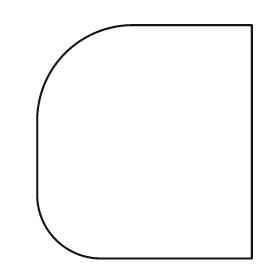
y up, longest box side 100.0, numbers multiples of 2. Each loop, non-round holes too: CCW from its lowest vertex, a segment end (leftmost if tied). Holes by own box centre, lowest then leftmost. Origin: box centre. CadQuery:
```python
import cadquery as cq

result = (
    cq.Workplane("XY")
    .moveTo(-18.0, -50.0)
    .lineTo(46.0, -50.0)
    .lineTo(46.0, 50.0)
    .lineTo(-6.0, 50.0)
    .threePointArc((-34.0, 38.0), (-46.0, 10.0))
    .lineTo(-46.0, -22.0)
    .threePointArc((-38.0, -42.0), (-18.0, -50.0))
    .close()
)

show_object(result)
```